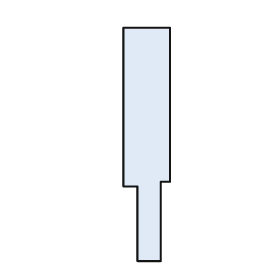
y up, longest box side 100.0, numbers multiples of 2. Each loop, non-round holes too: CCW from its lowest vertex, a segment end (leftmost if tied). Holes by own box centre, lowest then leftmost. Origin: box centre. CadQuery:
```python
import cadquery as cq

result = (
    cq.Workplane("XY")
    .moveTo(-4.0, -50.0)
    .lineTo(6.0, -50.0)
    .lineTo(6.0, -16.0)
    .lineTo(10.0, -16.0)
    .lineTo(10.0, 50.0)
    .lineTo(-10.0, 50.0)
    .lineTo(-10.0, -18.0)
    .lineTo(-4.0, -18.0)
    .close()
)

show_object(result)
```